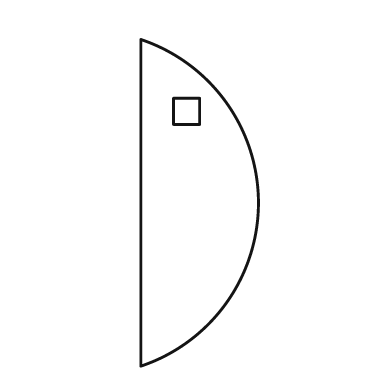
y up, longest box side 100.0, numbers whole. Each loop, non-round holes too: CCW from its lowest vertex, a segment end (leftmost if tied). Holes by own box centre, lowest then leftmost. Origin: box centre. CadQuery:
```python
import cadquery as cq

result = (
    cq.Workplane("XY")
    .moveTo(-18.0, -50.0)
    .threePointArc((18.0, 0.0), (-18.0, 50.0))
    .close()
    .moveTo(-8.0, 24.0)
    .lineTo(0.0, 24.0)
    .lineTo(0.0, 32.0)
    .lineTo(-8.0, 32.0)
    .close()
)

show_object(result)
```